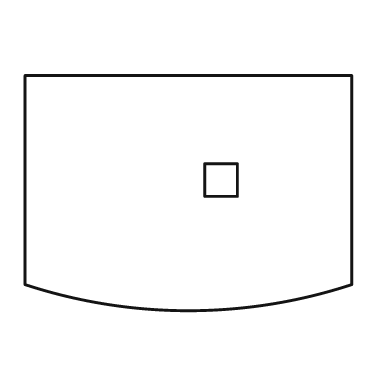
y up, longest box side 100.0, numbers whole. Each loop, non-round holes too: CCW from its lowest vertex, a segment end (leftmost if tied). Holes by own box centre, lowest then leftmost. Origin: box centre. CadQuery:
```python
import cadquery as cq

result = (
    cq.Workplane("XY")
    .moveTo(-50.0, -28.0)
    .threePointArc((0.0, -36.0), (50.0, -28.0))
    .lineTo(50.0, 36.0)
    .lineTo(-50.0, 36.0)
    .close()
    .moveTo(5.0, -1.0)
    .lineTo(15.0, -1.0)
    .lineTo(15.0, 9.0)
    .lineTo(5.0, 9.0)
    .close()
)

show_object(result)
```